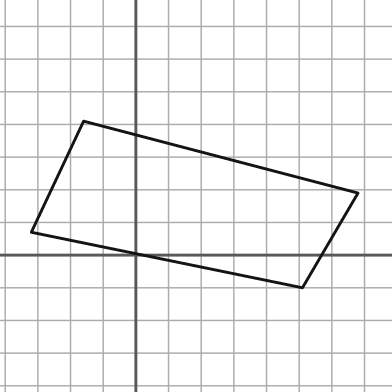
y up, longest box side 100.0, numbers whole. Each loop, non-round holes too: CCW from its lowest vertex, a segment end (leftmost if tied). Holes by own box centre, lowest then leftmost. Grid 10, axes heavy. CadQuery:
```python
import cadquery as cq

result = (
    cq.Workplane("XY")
    .moveTo(51.0, -10.0)
    .lineTo(68.0, 19.0)
    .lineTo(-16.0, 41.0)
    .lineTo(-32.0, 7.0)
    .close()
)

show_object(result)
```